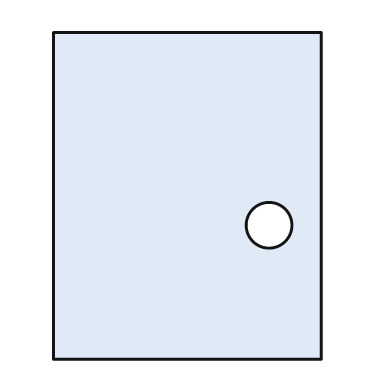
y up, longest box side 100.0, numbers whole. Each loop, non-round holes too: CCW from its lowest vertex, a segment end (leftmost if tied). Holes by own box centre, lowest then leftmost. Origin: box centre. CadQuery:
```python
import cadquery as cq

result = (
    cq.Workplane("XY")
    .moveTo(-41.0, -50.0)
    .lineTo(41.0, -50.0)
    .lineTo(41.0, 50.0)
    .lineTo(-41.0, 50.0)
    .close()
    .moveTo(25.0, -9.0)
    .circle(7.0)
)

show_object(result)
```